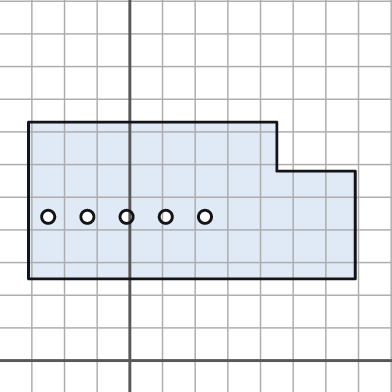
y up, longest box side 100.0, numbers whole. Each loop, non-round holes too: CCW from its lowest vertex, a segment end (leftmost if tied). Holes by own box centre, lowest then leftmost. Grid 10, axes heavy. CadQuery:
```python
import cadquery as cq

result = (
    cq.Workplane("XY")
    .moveTo(-31.0, 25.0)
    .lineTo(69.0, 25.0)
    .lineTo(69.0, 58.0)
    .lineTo(45.0, 58.0)
    .lineTo(45.0, 73.0)
    .lineTo(-31.0, 73.0)
    .close()
    .moveTo(-25.0, 44.0)
    .circle(2.0)
    .moveTo(-13.0, 44.0)
    .circle(2.0)
    .moveTo(-1.0, 44.0)
    .circle(2.0)
    .moveTo(11.0, 44.0)
    .circle(2.0)
    .moveTo(23.0, 44.0)
    .circle(2.0)
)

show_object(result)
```